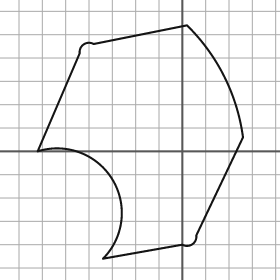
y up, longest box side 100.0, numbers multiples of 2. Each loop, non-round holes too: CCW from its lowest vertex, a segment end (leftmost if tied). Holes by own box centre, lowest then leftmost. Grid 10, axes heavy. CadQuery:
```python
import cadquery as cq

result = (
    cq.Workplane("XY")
    .moveTo(-34.0, -46.0)
    .lineTo(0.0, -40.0)
    .threePointArc((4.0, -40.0), (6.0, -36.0))
    .lineTo(26.0, 6.0)
    .threePointArc((18.0, 32.0), (2.0, 54.0))
    .lineTo(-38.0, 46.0)
    .threePointArc((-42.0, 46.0), (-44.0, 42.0))
    .lineTo(-62.0, 0.0)
    .threePointArc((-30.0, -12.0), (-34.0, -46.0))
    .close()
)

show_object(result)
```